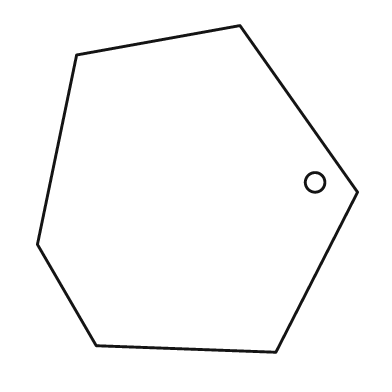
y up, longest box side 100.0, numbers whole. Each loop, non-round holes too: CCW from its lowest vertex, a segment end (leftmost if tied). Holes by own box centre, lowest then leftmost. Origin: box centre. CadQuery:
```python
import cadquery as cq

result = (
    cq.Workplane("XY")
    .moveTo(24.0, -50.0)
    .lineTo(49.0, -1.0)
    .lineTo(13.0, 50.0)
    .lineTo(-37.0, 41.0)
    .lineTo(-49.0, -17.0)
    .lineTo(-31.0, -48.0)
    .close()
    .moveTo(36.0, 2.0)
    .circle(3.0)
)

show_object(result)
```